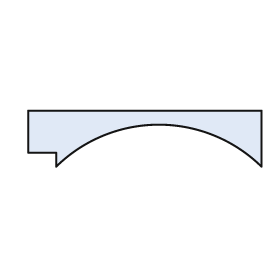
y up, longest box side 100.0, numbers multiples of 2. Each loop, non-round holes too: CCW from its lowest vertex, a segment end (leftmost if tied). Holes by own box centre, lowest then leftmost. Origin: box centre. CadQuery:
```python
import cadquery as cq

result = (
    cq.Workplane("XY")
    .moveTo(-38.0, -12.0)
    .threePointArc((6.0, 6.0), (50.0, -12.0))
    .lineTo(50.0, 12.0)
    .lineTo(-50.0, 12.0)
    .lineTo(-50.0, -6.0)
    .lineTo(-38.0, -6.0)
    .close()
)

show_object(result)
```